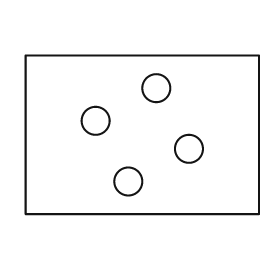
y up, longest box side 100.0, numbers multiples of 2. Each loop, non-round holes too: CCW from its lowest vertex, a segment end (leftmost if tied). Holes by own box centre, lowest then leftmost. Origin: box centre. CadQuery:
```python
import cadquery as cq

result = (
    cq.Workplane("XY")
    .moveTo(-50.0, -34.0)
    .lineTo(50.0, -34.0)
    .lineTo(50.0, 34.0)
    .lineTo(-50.0, 34.0)
    .close()
    .moveTo(-6.0, -20.0)
    .circle(6.0)
    .moveTo(20.0, -6.0)
    .circle(6.0)
    .moveTo(-20.0, 6.0)
    .circle(6.0)
    .moveTo(6.0, 20.0)
    .circle(6.0)
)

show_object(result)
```